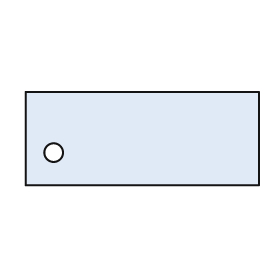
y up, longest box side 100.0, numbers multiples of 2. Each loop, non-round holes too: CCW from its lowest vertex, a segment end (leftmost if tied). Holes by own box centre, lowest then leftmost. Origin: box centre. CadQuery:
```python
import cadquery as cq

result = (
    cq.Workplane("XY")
    .moveTo(-50.0, -20.0)
    .lineTo(50.0, -20.0)
    .lineTo(50.0, 20.0)
    .lineTo(-50.0, 20.0)
    .close()
    .moveTo(-38.0, -6.0)
    .circle(4.0)
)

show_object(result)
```